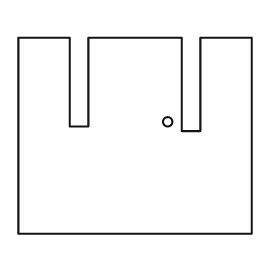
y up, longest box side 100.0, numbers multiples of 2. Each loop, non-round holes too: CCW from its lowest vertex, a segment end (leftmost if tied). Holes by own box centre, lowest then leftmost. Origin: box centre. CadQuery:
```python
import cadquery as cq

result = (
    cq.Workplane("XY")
    .moveTo(-50.0, -42.0)
    .lineTo(50.0, -42.0)
    .lineTo(50.0, 42.0)
    .lineTo(28.0, 42.0)
    .lineTo(28.0, 2.0)
    .lineTo(20.0, 2.0)
    .lineTo(20.0, 42.0)
    .lineTo(-20.0, 42.0)
    .lineTo(-20.0, 4.0)
    .lineTo(-28.0, 4.0)
    .lineTo(-28.0, 42.0)
    .lineTo(-50.0, 42.0)
    .close()
    .moveTo(14.0, 6.0)
    .circle(2.0)
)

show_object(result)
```